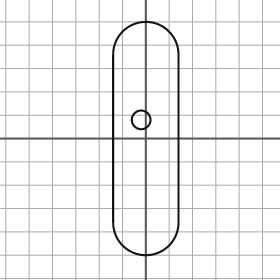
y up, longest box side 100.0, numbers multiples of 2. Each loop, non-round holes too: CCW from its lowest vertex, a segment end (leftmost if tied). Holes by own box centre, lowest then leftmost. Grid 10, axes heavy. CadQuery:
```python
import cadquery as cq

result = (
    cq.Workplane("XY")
    .moveTo(-14.0, -36.0)
    .threePointArc((0.0, -50.0), (14.0, -36.0))
    .lineTo(14.0, 36.0)
    .threePointArc((0.0, 50.0), (-14.0, 36.0))
    .close()
    .moveTo(-2.0, 8.0)
    .circle(4.0)
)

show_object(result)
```